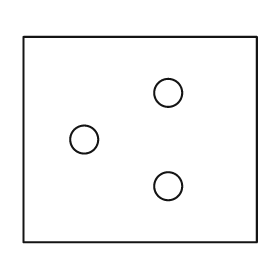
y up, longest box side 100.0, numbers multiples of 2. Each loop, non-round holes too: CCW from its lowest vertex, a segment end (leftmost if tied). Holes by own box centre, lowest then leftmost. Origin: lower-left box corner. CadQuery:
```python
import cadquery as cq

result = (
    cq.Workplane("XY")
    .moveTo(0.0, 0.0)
    .lineTo(100.0, 0.0)
    .lineTo(100.0, 88.0)
    .lineTo(0.0, 88.0)
    .close()
    .moveTo(62.0, 24.0)
    .circle(6.0)
    .moveTo(26.0, 44.0)
    .circle(6.0)
    .moveTo(62.0, 64.0)
    .circle(6.0)
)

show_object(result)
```